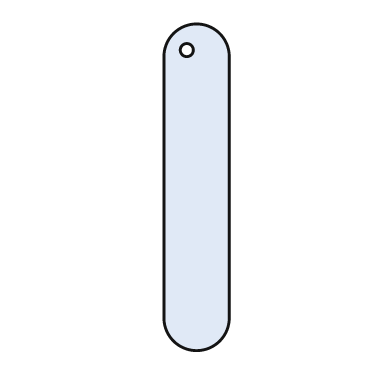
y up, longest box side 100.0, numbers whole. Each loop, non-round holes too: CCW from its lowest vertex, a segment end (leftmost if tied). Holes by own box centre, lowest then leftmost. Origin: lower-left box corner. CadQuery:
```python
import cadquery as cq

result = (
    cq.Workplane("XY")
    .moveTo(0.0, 10.0)
    .threePointArc((10.0, 0.0), (20.0, 10.0))
    .lineTo(20.0, 90.0)
    .threePointArc((10.0, 100.0), (0.0, 90.0))
    .close()
    .moveTo(7.0, 92.0)
    .circle(2.0)
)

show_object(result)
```